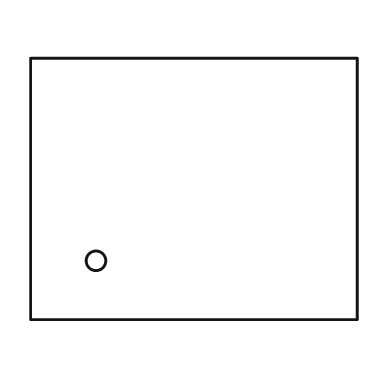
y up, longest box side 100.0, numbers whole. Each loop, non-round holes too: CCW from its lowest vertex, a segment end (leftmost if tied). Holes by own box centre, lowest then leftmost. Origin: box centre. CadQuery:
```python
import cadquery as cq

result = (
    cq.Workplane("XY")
    .moveTo(-50.0, -40.0)
    .lineTo(50.0, -40.0)
    .lineTo(50.0, 40.0)
    .lineTo(-50.0, 40.0)
    .close()
    .moveTo(-30.0, -22.0)
    .circle(3.0)
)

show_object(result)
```